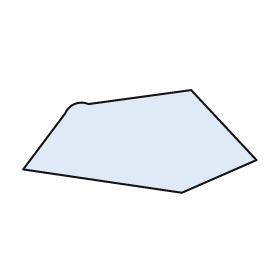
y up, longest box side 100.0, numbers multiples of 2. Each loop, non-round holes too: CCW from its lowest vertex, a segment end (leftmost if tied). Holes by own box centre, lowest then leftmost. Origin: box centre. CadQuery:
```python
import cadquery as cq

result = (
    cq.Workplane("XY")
    .moveTo(18.0, -22.0)
    .lineTo(50.0, -8.0)
    .lineTo(22.0, 22.0)
    .lineTo(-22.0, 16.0)
    .threePointArc((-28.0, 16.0), (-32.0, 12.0))
    .lineTo(-50.0, -12.0)
    .close()
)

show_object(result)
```